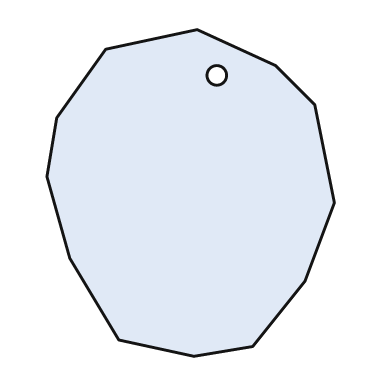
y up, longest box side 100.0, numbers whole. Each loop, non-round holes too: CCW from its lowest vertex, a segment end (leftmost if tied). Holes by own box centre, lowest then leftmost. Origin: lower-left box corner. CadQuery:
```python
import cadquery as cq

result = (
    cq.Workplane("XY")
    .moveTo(45.0, 0.0)
    .lineTo(63.0, 3.0)
    .lineTo(79.0, 23.0)
    .lineTo(88.0, 47.0)
    .lineTo(82.0, 77.0)
    .lineTo(70.0, 89.0)
    .lineTo(46.0, 100.0)
    .lineTo(18.0, 94.0)
    .lineTo(3.0, 73.0)
    .lineTo(0.0, 55.0)
    .lineTo(7.0, 30.0)
    .lineTo(22.0, 5.0)
    .close()
    .moveTo(52.0, 86.0)
    .circle(3.0)
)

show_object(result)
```